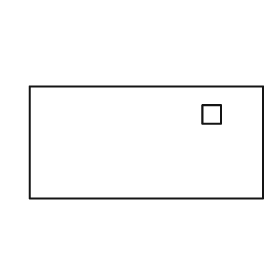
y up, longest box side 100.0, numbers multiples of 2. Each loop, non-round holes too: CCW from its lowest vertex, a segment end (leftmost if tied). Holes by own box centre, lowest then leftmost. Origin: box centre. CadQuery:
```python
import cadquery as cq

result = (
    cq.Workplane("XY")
    .moveTo(-50.0, -24.0)
    .lineTo(50.0, -24.0)
    .lineTo(50.0, 24.0)
    .lineTo(-50.0, 24.0)
    .close()
    .moveTo(24.0, 8.0)
    .lineTo(32.0, 8.0)
    .lineTo(32.0, 16.0)
    .lineTo(24.0, 16.0)
    .close()
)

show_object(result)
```